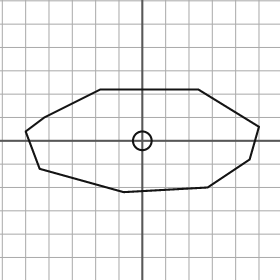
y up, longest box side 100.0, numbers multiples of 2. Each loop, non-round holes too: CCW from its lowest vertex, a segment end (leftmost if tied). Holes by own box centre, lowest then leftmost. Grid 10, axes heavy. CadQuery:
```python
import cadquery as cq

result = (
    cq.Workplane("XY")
    .moveTo(-8.0, -22.0)
    .lineTo(28.0, -20.0)
    .lineTo(46.0, -8.0)
    .lineTo(50.0, 6.0)
    .lineTo(24.0, 22.0)
    .lineTo(-18.0, 22.0)
    .lineTo(-42.0, 10.0)
    .lineTo(-50.0, 4.0)
    .lineTo(-44.0, -12.0)
    .close()
    .moveTo(0.0, 0.0)
    .circle(4.0)
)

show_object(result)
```